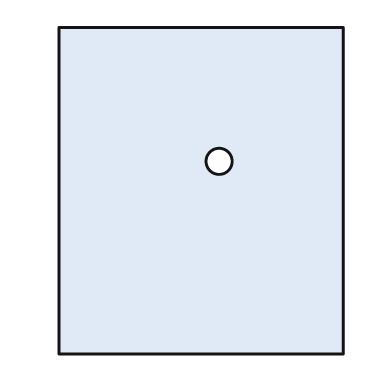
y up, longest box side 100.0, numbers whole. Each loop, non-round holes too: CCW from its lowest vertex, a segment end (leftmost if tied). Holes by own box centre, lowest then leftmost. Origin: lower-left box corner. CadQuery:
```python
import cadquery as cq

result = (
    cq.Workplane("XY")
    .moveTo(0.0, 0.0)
    .lineTo(87.0, 0.0)
    .lineTo(87.0, 100.0)
    .lineTo(0.0, 100.0)
    .close()
    .moveTo(49.0, 59.0)
    .circle(4.0)
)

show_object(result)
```